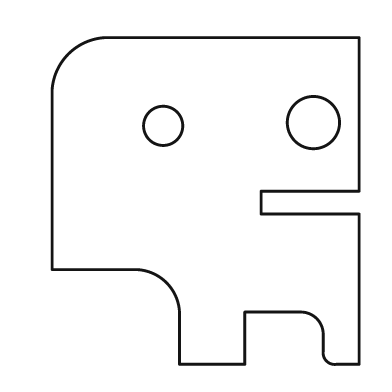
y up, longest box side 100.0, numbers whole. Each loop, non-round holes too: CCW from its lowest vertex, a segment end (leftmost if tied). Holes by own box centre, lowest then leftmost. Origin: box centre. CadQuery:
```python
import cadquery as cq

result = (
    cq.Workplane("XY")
    .moveTo(-8.0, -50.0)
    .lineTo(12.0, -50.0)
    .lineTo(12.0, -34.0)
    .lineTo(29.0, -34.0)
    .threePointArc((34.0, -36.0), (36.0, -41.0))
    .lineTo(36.0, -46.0)
    .threePointArc((37.0, -49.0), (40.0, -50.0))
    .lineTo(47.0, -50.0)
    .lineTo(47.0, -4.0)
    .lineTo(17.0, -4.0)
    .lineTo(17.0, 3.0)
    .lineTo(47.0, 3.0)
    .lineTo(47.0, 50.0)
    .lineTo(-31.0, 50.0)
    .threePointArc((-42.0, 45.0), (-47.0, 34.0))
    .lineTo(-47.0, -21.0)
    .lineTo(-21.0, -21.0)
    .threePointArc((-12.0, -25.0), (-8.0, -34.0))
    .close()
    .moveTo(-13.0, 23.0)
    .circle(6.0)
    .moveTo(33.0, 24.0)
    .circle(8.0)
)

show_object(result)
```